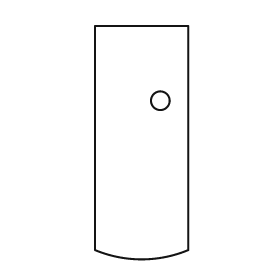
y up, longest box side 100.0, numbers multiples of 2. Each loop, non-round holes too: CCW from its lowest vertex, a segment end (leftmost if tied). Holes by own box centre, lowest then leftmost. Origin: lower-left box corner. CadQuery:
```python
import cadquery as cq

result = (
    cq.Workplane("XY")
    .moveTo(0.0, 4.0)
    .threePointArc((20.0, 0.0), (40.0, 4.0))
    .lineTo(40.0, 100.0)
    .lineTo(0.0, 100.0)
    .close()
    .moveTo(28.0, 68.0)
    .circle(4.0)
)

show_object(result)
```